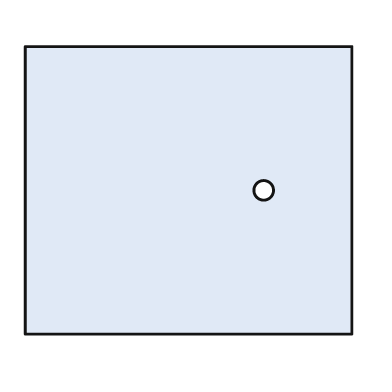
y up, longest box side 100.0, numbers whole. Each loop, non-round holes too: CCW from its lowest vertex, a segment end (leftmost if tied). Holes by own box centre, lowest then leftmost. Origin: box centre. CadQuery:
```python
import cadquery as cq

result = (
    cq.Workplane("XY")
    .moveTo(-50.0, -44.0)
    .lineTo(50.0, -44.0)
    .lineTo(50.0, 44.0)
    .lineTo(-50.0, 44.0)
    .close()
    .moveTo(23.0, 0.0)
    .circle(3.0)
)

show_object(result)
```